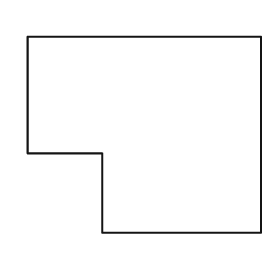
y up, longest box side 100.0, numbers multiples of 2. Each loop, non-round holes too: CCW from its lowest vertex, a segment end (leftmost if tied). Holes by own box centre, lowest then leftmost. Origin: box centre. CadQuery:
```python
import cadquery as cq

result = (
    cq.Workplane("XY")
    .moveTo(-18.0, -42.0)
    .lineTo(50.0, -42.0)
    .lineTo(50.0, 42.0)
    .lineTo(-50.0, 42.0)
    .lineTo(-50.0, -8.0)
    .lineTo(-18.0, -8.0)
    .close()
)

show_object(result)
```